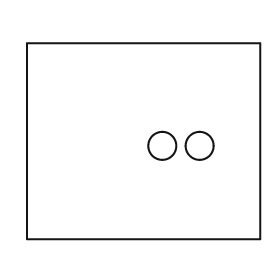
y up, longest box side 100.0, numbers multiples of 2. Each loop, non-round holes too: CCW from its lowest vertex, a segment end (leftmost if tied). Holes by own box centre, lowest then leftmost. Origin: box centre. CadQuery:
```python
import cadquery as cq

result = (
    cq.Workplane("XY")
    .moveTo(-50.0, -42.0)
    .lineTo(50.0, -42.0)
    .lineTo(50.0, 42.0)
    .lineTo(-50.0, 42.0)
    .close()
    .moveTo(8.0, -2.0)
    .circle(6.0)
    .moveTo(24.0, -2.0)
    .circle(6.0)
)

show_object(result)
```